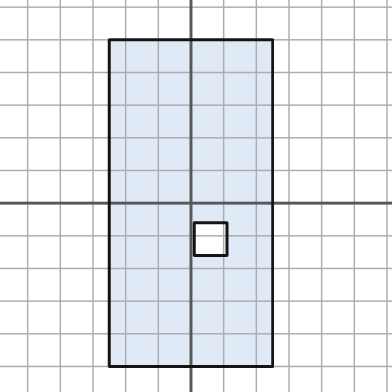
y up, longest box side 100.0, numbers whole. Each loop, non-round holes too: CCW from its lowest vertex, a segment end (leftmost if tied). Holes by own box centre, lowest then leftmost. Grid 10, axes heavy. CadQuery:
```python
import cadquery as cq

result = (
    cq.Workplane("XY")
    .moveTo(-25.0, -50.0)
    .lineTo(25.0, -50.0)
    .lineTo(25.0, 50.0)
    .lineTo(-25.0, 50.0)
    .close()
    .moveTo(1.0, -16.0)
    .lineTo(11.0, -16.0)
    .lineTo(11.0, -6.0)
    .lineTo(1.0, -6.0)
    .close()
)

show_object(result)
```